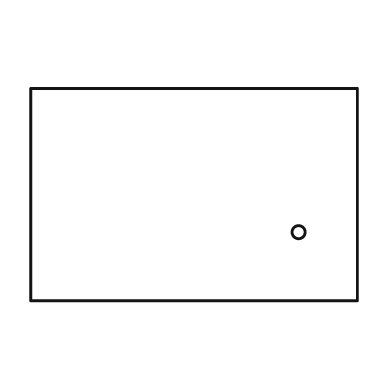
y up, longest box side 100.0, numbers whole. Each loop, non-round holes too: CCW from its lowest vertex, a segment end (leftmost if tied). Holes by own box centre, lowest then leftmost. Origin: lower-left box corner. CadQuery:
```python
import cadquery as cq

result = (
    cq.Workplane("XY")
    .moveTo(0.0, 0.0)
    .lineTo(100.0, 0.0)
    .lineTo(100.0, 65.0)
    .lineTo(0.0, 65.0)
    .close()
    .moveTo(82.0, 21.0)
    .circle(2.0)
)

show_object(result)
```